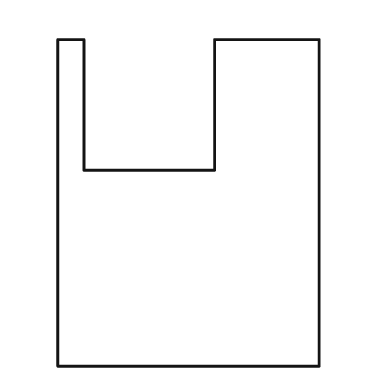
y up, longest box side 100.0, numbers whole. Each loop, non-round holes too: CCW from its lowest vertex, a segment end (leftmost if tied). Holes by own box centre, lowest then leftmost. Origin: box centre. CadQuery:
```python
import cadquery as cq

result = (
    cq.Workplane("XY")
    .moveTo(-40.0, -50.0)
    .lineTo(40.0, -50.0)
    .lineTo(40.0, 50.0)
    .lineTo(8.0, 50.0)
    .lineTo(8.0, 10.0)
    .lineTo(-32.0, 10.0)
    .lineTo(-32.0, 50.0)
    .lineTo(-40.0, 50.0)
    .close()
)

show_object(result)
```